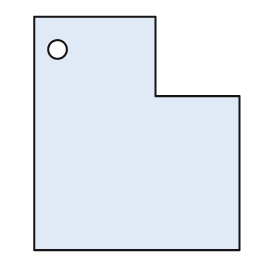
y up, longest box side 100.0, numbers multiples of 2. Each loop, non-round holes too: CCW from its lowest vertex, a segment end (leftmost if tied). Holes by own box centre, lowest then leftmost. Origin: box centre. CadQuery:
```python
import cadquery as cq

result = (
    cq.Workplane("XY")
    .moveTo(-44.0, -50.0)
    .lineTo(44.0, -50.0)
    .lineTo(44.0, 16.0)
    .lineTo(8.0, 16.0)
    .lineTo(8.0, 50.0)
    .lineTo(-44.0, 50.0)
    .close()
    .moveTo(-34.0, 36.0)
    .circle(4.0)
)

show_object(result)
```